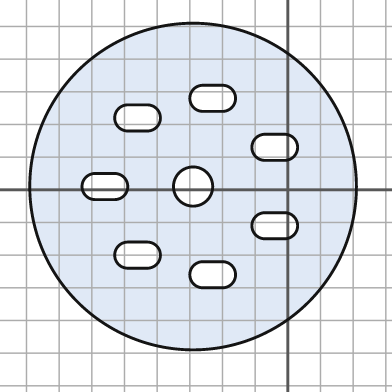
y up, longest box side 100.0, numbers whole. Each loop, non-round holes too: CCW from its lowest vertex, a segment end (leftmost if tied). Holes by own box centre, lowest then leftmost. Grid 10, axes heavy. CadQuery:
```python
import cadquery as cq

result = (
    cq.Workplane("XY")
    .moveTo(-29.0, 1.0)
    .circle(50.0)
    .moveTo(-26.0, -30.0)
    .lineTo(-20.0, -30.0)
    .threePointArc((-16.0, -26.0), (-20.0, -22.0))
    .lineTo(-26.0, -22.0)
    .threePointArc((-30.0, -26.0), (-26.0, -30.0))
    .close()
    .moveTo(-49.0, -24.0)
    .lineTo(-43.0, -24.0)
    .threePointArc((-39.0, -20.0), (-43.0, -16.0))
    .lineTo(-49.0, -16.0)
    .threePointArc((-53.0, -20.0), (-49.0, -24.0))
    .close()
    .moveTo(-7.0, -15.0)
    .lineTo(-1.0, -15.0)
    .threePointArc((3.0, -11.0), (-1.0, -7.0))
    .lineTo(-7.0, -7.0)
    .threePointArc((-11.0, -11.0), (-7.0, -15.0))
    .close()
    .moveTo(-59.0, -3.0)
    .lineTo(-53.0, -3.0)
    .threePointArc((-49.0, 1.0), (-53.0, 5.0))
    .lineTo(-59.0, 5.0)
    .threePointArc((-63.0, 1.0), (-59.0, -3.0))
    .close()
    .moveTo(-29.0, 1.0)
    .circle(6.0)
    .moveTo(-7.0, 9.0)
    .lineTo(-1.0, 9.0)
    .threePointArc((3.0, 13.0), (-1.0, 17.0))
    .lineTo(-7.0, 17.0)
    .threePointArc((-11.0, 13.0), (-7.0, 9.0))
    .close()
    .moveTo(-49.0, 18.0)
    .lineTo(-43.0, 18.0)
    .threePointArc((-39.0, 22.0), (-43.0, 26.0))
    .lineTo(-49.0, 26.0)
    .threePointArc((-53.0, 22.0), (-49.0, 18.0))
    .close()
    .moveTo(-26.0, 24.0)
    .lineTo(-20.0, 24.0)
    .threePointArc((-16.0, 28.0), (-20.0, 32.0))
    .lineTo(-26.0, 32.0)
    .threePointArc((-30.0, 28.0), (-26.0, 24.0))
    .close()
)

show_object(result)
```